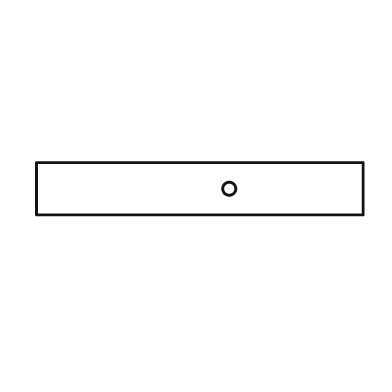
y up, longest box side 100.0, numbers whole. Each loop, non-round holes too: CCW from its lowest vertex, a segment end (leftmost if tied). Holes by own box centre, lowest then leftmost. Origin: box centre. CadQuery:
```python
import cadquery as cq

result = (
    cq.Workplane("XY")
    .moveTo(-50.0, -8.0)
    .lineTo(50.0, -8.0)
    .lineTo(50.0, 8.0)
    .lineTo(-50.0, 8.0)
    .close()
    .moveTo(9.0, 0.0)
    .circle(2.0)
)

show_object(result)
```